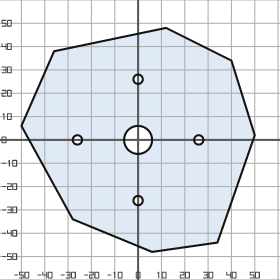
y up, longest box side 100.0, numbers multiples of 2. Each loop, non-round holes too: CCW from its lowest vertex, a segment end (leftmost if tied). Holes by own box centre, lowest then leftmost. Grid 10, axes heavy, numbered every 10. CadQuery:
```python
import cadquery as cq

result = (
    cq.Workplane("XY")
    .moveTo(6.0, -48.0)
    .lineTo(34.0, -44.0)
    .lineTo(50.0, 2.0)
    .lineTo(40.0, 34.0)
    .lineTo(12.0, 48.0)
    .lineTo(-36.0, 38.0)
    .lineTo(-50.0, 6.0)
    .lineTo(-28.0, -34.0)
    .close()
    .moveTo(0.0, -26.0)
    .circle(2.0)
    .moveTo(-26.0, 0.0)
    .circle(2.0)
    .moveTo(0.0, 0.0)
    .circle(6.0)
    .moveTo(26.0, 0.0)
    .circle(2.0)
    .moveTo(0.0, 26.0)
    .circle(2.0)
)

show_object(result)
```